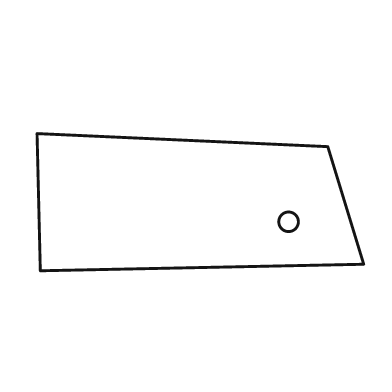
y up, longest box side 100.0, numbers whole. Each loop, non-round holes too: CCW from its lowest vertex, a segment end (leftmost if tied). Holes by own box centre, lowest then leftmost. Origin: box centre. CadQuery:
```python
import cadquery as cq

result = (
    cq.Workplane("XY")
    .moveTo(-49.0, -21.0)
    .lineTo(50.0, -19.0)
    .lineTo(39.0, 17.0)
    .lineTo(-50.0, 21.0)
    .close()
    .moveTo(27.0, -6.0)
    .circle(3.0)
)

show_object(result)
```